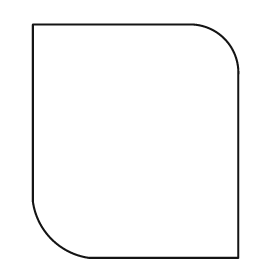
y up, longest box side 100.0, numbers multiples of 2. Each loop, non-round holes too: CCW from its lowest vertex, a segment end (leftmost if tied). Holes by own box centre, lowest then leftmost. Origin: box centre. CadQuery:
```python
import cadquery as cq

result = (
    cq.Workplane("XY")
    .moveTo(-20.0, -50.0)
    .lineTo(44.0, -50.0)
    .lineTo(44.0, 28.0)
    .threePointArc((38.0, 44.0), (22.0, 50.0))
    .lineTo(-44.0, 50.0)
    .lineTo(-44.0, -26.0)
    .threePointArc((-36.0, -42.0), (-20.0, -50.0))
    .close()
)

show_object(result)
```